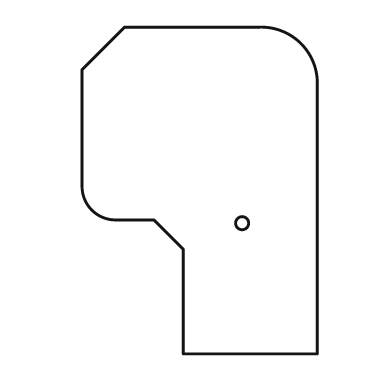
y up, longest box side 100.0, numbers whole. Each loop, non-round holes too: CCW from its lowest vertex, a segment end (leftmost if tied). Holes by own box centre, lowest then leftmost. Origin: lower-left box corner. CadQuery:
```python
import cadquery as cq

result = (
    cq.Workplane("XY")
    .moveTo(31.0, 0.0)
    .lineTo(72.0, 0.0)
    .lineTo(72.0, 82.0)
    .threePointArc((67.0, 95.0), (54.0, 100.0))
    .lineTo(13.0, 100.0)
    .lineTo(0.0, 87.0)
    .lineTo(0.0, 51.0)
    .threePointArc((3.0, 44.0), (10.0, 41.0))
    .lineTo(22.0, 41.0)
    .lineTo(31.0, 32.0)
    .close()
    .moveTo(49.0, 40.0)
    .circle(2.0)
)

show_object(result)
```